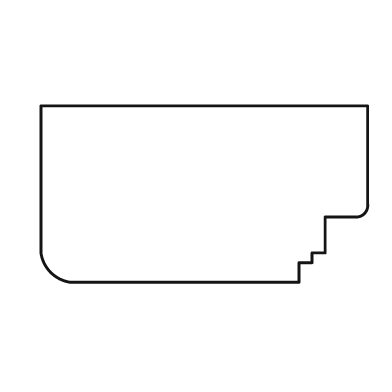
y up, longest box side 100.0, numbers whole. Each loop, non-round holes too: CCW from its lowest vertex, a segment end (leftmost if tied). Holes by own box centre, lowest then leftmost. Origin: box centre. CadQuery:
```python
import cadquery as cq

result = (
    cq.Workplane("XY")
    .moveTo(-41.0, -27.0)
    .lineTo(29.0, -27.0)
    .lineTo(29.0, -21.0)
    .lineTo(33.0, -21.0)
    .lineTo(33.0, -18.0)
    .lineTo(37.0, -18.0)
    .lineTo(37.0, -7.0)
    .lineTo(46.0, -7.0)
    .threePointArc((49.0, -6.0), (50.0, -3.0))
    .lineTo(50.0, 27.0)
    .lineTo(-50.0, 27.0)
    .lineTo(-50.0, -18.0)
    .threePointArc((-47.0, -24.0), (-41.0, -27.0))
    .close()
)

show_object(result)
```